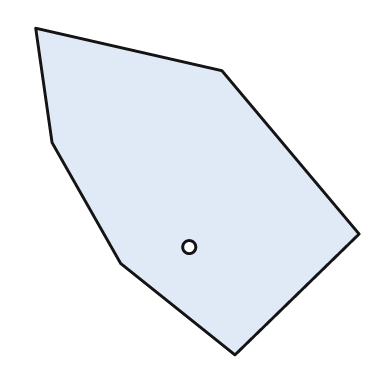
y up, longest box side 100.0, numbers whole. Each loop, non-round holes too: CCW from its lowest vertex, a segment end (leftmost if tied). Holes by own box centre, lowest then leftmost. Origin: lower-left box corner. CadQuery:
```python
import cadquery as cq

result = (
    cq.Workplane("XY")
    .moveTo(61.0, 0.0)
    .lineTo(99.0, 37.0)
    .lineTo(57.0, 87.0)
    .lineTo(0.0, 100.0)
    .lineTo(5.0, 65.0)
    .lineTo(26.0, 28.0)
    .close()
    .moveTo(47.0, 33.0)
    .circle(2.0)
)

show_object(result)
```